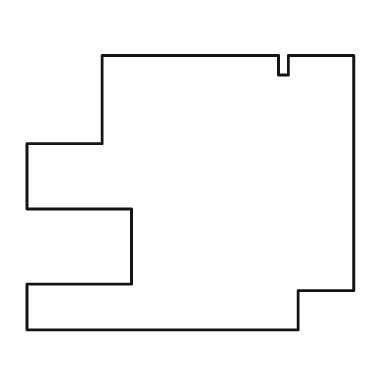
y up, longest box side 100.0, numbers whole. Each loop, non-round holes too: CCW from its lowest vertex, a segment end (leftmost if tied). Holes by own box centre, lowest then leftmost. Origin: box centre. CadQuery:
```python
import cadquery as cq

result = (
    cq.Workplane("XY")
    .moveTo(-50.0, -42.0)
    .lineTo(33.0, -42.0)
    .lineTo(33.0, -30.0)
    .lineTo(50.0, -30.0)
    .lineTo(50.0, 42.0)
    .lineTo(30.0, 42.0)
    .lineTo(30.0, 36.0)
    .lineTo(27.0, 36.0)
    .lineTo(27.0, 42.0)
    .lineTo(-27.0, 42.0)
    .lineTo(-27.0, 15.0)
    .lineTo(-50.0, 15.0)
    .lineTo(-50.0, -5.0)
    .lineTo(-18.0, -5.0)
    .lineTo(-18.0, -28.0)
    .lineTo(-50.0, -28.0)
    .close()
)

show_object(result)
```